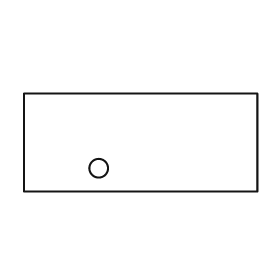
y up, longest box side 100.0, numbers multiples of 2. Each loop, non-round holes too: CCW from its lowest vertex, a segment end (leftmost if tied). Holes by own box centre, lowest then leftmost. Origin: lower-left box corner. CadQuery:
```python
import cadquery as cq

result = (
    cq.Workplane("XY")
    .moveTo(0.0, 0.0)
    .lineTo(100.0, 0.0)
    .lineTo(100.0, 42.0)
    .lineTo(0.0, 42.0)
    .close()
    .moveTo(32.0, 10.0)
    .circle(4.0)
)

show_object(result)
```